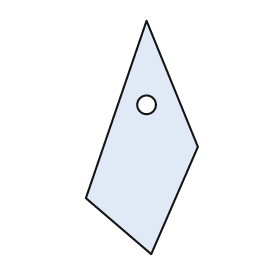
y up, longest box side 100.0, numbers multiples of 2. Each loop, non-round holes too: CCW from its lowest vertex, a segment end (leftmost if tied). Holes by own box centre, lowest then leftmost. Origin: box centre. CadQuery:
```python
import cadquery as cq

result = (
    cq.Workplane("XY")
    .moveTo(4.0, -50.0)
    .lineTo(24.0, -4.0)
    .lineTo(2.0, 50.0)
    .lineTo(-24.0, -26.0)
    .close()
    .moveTo(2.0, 14.0)
    .circle(4.0)
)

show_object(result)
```